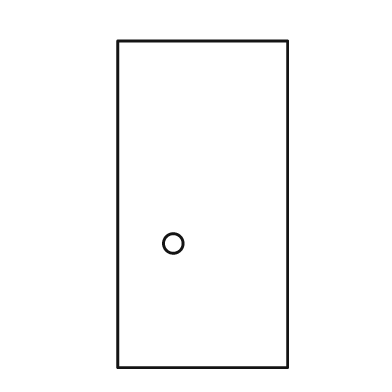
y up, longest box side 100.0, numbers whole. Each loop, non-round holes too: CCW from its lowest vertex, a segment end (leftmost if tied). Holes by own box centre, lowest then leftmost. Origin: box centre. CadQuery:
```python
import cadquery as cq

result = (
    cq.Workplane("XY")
    .moveTo(-26.0, -50.0)
    .lineTo(26.0, -50.0)
    .lineTo(26.0, 50.0)
    .lineTo(-26.0, 50.0)
    .close()
    .moveTo(-9.0, -12.0)
    .circle(3.0)
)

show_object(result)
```